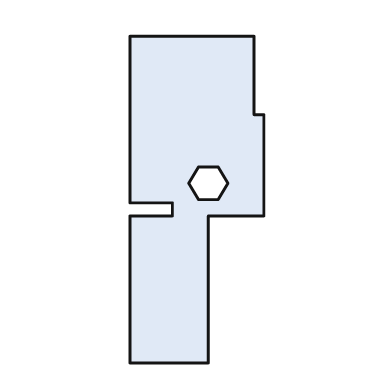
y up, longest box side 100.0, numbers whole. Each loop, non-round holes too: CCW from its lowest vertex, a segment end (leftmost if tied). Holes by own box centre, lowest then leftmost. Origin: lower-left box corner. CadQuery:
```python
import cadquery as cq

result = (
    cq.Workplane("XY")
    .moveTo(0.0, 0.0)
    .lineTo(24.0, 0.0)
    .lineTo(24.0, 45.0)
    .lineTo(41.0, 45.0)
    .lineTo(41.0, 76.0)
    .lineTo(38.0, 76.0)
    .lineTo(38.0, 100.0)
    .lineTo(0.0, 100.0)
    .lineTo(0.0, 49.0)
    .lineTo(13.0, 49.0)
    .lineTo(13.0, 45.0)
    .lineTo(0.0, 45.0)
    .close()
    .moveTo(21.0, 50.0)
    .lineTo(27.0, 50.0)
    .lineTo(30.0, 55.0)
    .lineTo(27.0, 60.0)
    .lineTo(21.0, 60.0)
    .lineTo(18.0, 55.0)
    .close()
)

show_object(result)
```